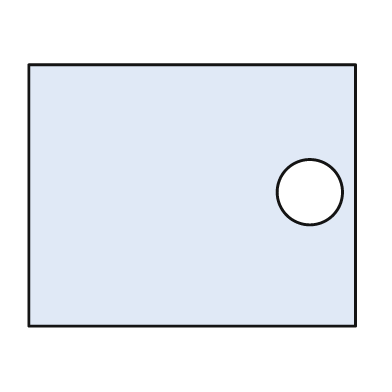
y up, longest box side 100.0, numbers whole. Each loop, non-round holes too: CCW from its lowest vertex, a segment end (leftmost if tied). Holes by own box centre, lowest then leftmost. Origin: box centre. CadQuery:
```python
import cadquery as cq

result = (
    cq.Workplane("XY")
    .moveTo(-50.0, -40.0)
    .lineTo(50.0, -40.0)
    .lineTo(50.0, 40.0)
    .lineTo(-50.0, 40.0)
    .close()
    .moveTo(36.0, 1.0)
    .circle(10.0)
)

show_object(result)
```